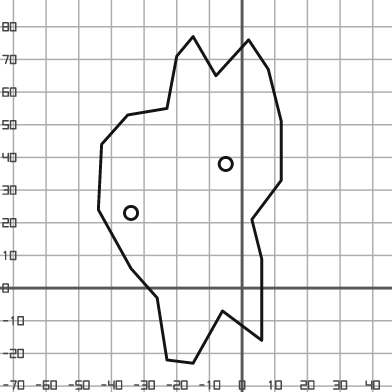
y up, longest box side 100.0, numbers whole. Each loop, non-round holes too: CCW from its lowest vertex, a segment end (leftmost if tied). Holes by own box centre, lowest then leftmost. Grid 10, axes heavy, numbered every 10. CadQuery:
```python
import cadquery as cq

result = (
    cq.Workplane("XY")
    .moveTo(-15.0, -23.0)
    .lineTo(-6.0, -7.0)
    .lineTo(6.0, -16.0)
    .lineTo(6.0, 9.0)
    .lineTo(3.0, 21.0)
    .lineTo(12.0, 33.0)
    .lineTo(12.0, 51.0)
    .lineTo(8.0, 67.0)
    .lineTo(2.0, 76.0)
    .lineTo(-8.0, 65.0)
    .lineTo(-15.0, 77.0)
    .lineTo(-20.0, 71.0)
    .lineTo(-23.0, 55.0)
    .lineTo(-35.0, 53.0)
    .lineTo(-43.0, 44.0)
    .lineTo(-44.0, 24.0)
    .lineTo(-34.0, 6.0)
    .lineTo(-26.0, -3.0)
    .lineTo(-23.0, -22.0)
    .close()
    .moveTo(-34.0, 23.0)
    .circle(2.0)
    .moveTo(-5.0, 38.0)
    .circle(2.0)
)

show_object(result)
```